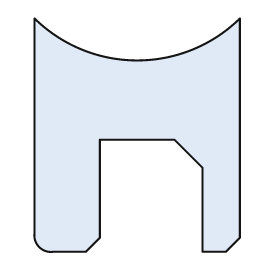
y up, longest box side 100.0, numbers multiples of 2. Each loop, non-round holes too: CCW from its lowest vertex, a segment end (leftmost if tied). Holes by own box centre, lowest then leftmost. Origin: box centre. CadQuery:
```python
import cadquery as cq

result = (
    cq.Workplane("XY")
    .moveTo(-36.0, -50.0)
    .lineTo(-22.0, -50.0)
    .lineTo(-16.0, -44.0)
    .lineTo(-16.0, -2.0)
    .lineTo(16.0, -2.0)
    .lineTo(28.0, -14.0)
    .lineTo(28.0, -50.0)
    .lineTo(38.0, -50.0)
    .lineTo(44.0, -44.0)
    .lineTo(44.0, 50.0)
    .threePointArc((0.0, 32.0), (-44.0, 50.0))
    .lineTo(-44.0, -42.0)
    .threePointArc((-42.0, -48.0), (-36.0, -50.0))
    .close()
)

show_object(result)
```